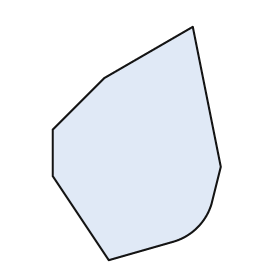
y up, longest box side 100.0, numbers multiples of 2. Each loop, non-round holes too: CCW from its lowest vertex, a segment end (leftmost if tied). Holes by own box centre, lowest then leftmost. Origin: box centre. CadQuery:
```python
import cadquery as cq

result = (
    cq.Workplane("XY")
    .moveTo(-12.0, -50.0)
    .lineTo(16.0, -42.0)
    .threePointArc((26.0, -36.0), (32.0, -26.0))
    .lineTo(36.0, -10.0)
    .lineTo(24.0, 50.0)
    .lineTo(-14.0, 28.0)
    .lineTo(-36.0, 6.0)
    .lineTo(-36.0, -14.0)
    .close()
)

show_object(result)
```